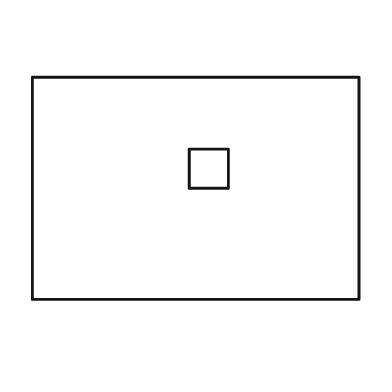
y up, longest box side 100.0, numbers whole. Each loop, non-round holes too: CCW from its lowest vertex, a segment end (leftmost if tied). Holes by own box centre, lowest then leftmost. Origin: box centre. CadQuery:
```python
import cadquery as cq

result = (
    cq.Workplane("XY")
    .moveTo(-50.0, -34.0)
    .lineTo(50.0, -34.0)
    .lineTo(50.0, 34.0)
    .lineTo(-50.0, 34.0)
    .close()
    .moveTo(-2.0, 0.0)
    .lineTo(10.0, 0.0)
    .lineTo(10.0, 12.0)
    .lineTo(-2.0, 12.0)
    .close()
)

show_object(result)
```